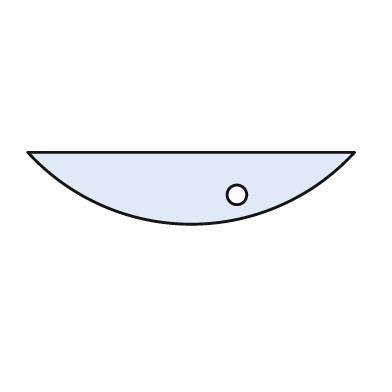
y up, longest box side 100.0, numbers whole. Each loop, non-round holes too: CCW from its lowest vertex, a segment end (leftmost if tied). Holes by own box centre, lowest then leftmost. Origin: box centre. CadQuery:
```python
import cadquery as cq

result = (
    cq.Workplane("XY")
    .moveTo(-50.0, 11.0)
    .threePointArc((0.0, -11.0), (50.0, 11.0))
    .close()
    .moveTo(14.0, -2.0)
    .circle(3.0)
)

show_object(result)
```